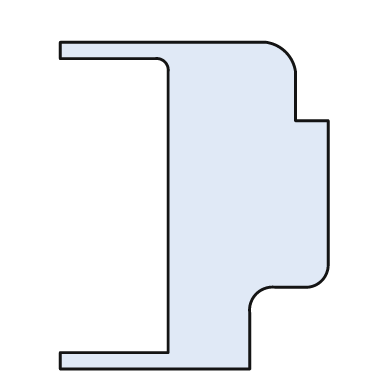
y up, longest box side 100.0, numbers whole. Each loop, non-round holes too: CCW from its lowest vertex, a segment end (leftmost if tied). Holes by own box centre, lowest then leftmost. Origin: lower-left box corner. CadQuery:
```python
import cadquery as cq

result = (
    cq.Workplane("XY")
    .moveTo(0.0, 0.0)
    .lineTo(58.0, 0.0)
    .lineTo(58.0, 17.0)
    .threePointArc((60.0, 23.0), (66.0, 25.0))
    .lineTo(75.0, 25.0)
    .threePointArc((80.0, 27.0), (82.0, 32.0))
    .lineTo(82.0, 76.0)
    .lineTo(72.0, 76.0)
    .lineTo(72.0, 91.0)
    .threePointArc((69.0, 97.0), (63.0, 100.0))
    .lineTo(0.0, 100.0)
    .lineTo(0.0, 95.0)
    .lineTo(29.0, 95.0)
    .threePointArc((32.0, 94.0), (33.0, 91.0))
    .lineTo(33.0, 5.0)
    .lineTo(0.0, 5.0)
    .close()
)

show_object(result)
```